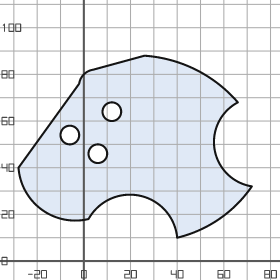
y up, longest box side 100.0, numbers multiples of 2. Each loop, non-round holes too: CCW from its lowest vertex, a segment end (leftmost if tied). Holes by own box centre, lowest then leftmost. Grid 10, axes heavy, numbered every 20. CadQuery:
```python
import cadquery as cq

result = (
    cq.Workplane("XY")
    .moveTo(40.0, 10.0)
    .threePointArc((58.0, 18.0), (72.0, 32.0))
    .threePointArc((56.0, 48.0), (66.0, 68.0))
    .threePointArc((48.0, 82.0), (26.0, 88.0))
    .lineTo(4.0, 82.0)
    .threePointArc((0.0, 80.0), (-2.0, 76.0))
    .lineTo(-28.0, 40.0)
    .threePointArc((-18.0, 22.0), (2.0, 18.0))
    .threePointArc((24.0, 28.0), (40.0, 10.0))
    .close()
    .moveTo(6.0, 46.0)
    .circle(4.0)
    .moveTo(-6.0, 54.0)
    .circle(4.0)
    .moveTo(12.0, 64.0)
    .circle(4.0)
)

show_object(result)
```